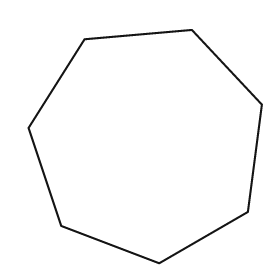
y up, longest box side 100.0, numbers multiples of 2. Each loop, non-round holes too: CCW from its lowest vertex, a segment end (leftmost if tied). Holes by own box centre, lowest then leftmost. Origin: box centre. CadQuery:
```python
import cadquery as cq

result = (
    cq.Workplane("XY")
    .moveTo(6.0, -50.0)
    .lineTo(44.0, -28.0)
    .lineTo(50.0, 18.0)
    .lineTo(20.0, 50.0)
    .lineTo(-26.0, 46.0)
    .lineTo(-50.0, 8.0)
    .lineTo(-36.0, -34.0)
    .close()
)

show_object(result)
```